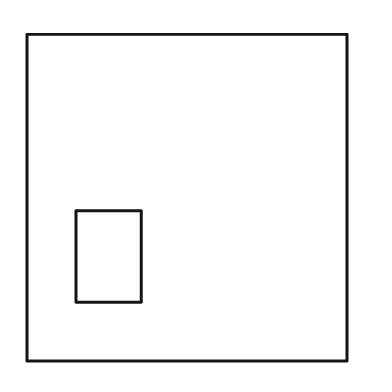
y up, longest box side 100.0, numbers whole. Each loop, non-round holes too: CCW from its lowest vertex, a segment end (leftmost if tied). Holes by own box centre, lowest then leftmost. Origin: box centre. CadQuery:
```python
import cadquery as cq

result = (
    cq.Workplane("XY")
    .moveTo(-49.0, -50.0)
    .lineTo(49.0, -50.0)
    .lineTo(49.0, 50.0)
    .lineTo(-49.0, 50.0)
    .close()
    .moveTo(-34.0, -32.0)
    .lineTo(-14.0, -32.0)
    .lineTo(-14.0, -4.0)
    .lineTo(-34.0, -4.0)
    .close()
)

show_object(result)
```